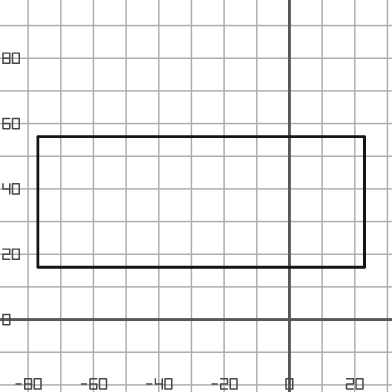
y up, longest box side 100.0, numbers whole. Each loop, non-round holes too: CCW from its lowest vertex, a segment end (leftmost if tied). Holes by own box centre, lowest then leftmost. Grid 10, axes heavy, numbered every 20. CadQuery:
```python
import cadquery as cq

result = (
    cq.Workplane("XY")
    .moveTo(-77.0, 16.0)
    .lineTo(23.0, 16.0)
    .lineTo(23.0, 56.0)
    .lineTo(-77.0, 56.0)
    .close()
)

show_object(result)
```